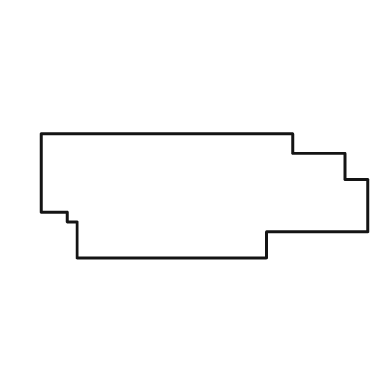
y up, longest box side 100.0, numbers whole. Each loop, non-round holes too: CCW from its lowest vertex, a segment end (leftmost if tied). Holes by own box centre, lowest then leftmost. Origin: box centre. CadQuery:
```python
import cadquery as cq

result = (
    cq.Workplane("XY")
    .moveTo(-39.0, -19.0)
    .lineTo(19.0, -19.0)
    .lineTo(19.0, -11.0)
    .lineTo(50.0, -11.0)
    .lineTo(50.0, 5.0)
    .lineTo(43.0, 5.0)
    .lineTo(43.0, 13.0)
    .lineTo(27.0, 13.0)
    .lineTo(27.0, 19.0)
    .lineTo(-50.0, 19.0)
    .lineTo(-50.0, -5.0)
    .lineTo(-42.0, -5.0)
    .lineTo(-42.0, -8.0)
    .lineTo(-39.0, -8.0)
    .close()
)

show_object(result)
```